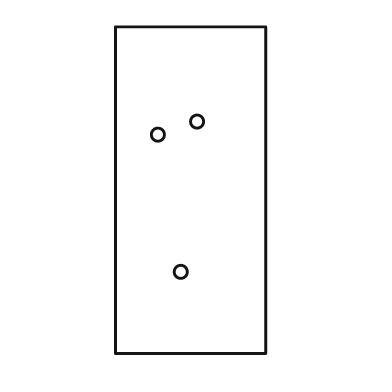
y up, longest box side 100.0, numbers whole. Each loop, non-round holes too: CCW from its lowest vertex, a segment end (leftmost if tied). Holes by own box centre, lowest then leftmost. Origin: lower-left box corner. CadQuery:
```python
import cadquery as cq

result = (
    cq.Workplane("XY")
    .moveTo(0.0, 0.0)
    .lineTo(46.0, 0.0)
    .lineTo(46.0, 100.0)
    .lineTo(0.0, 100.0)
    .close()
    .moveTo(20.0, 25.0)
    .circle(2.0)
    .moveTo(13.0, 67.0)
    .circle(2.0)
    .moveTo(25.0, 71.0)
    .circle(2.0)
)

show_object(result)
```